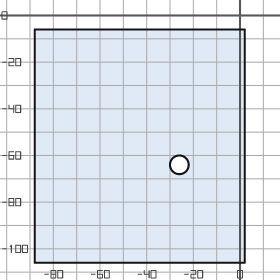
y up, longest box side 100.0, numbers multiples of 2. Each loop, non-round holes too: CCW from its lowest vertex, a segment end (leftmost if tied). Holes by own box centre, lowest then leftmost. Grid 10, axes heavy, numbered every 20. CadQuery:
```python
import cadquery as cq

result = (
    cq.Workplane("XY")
    .moveTo(-88.0, -106.0)
    .lineTo(2.0, -106.0)
    .lineTo(2.0, -6.0)
    .lineTo(-88.0, -6.0)
    .close()
    .moveTo(-26.0, -64.0)
    .circle(4.0)
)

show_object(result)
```